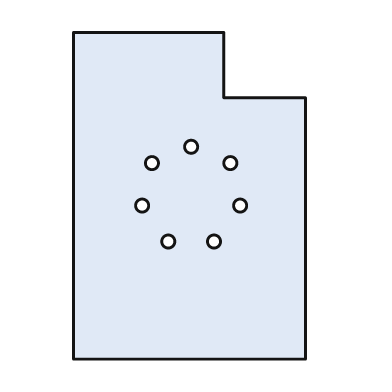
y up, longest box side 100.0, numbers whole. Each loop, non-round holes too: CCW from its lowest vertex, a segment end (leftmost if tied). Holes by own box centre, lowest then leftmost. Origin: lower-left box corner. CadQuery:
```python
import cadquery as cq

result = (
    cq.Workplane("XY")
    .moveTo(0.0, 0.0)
    .lineTo(71.0, 0.0)
    .lineTo(71.0, 80.0)
    .lineTo(46.0, 80.0)
    .lineTo(46.0, 100.0)
    .lineTo(0.0, 100.0)
    .close()
    .moveTo(29.0, 36.0)
    .circle(2.0)
    .moveTo(43.0, 36.0)
    .circle(2.0)
    .moveTo(21.0, 47.0)
    .circle(2.0)
    .moveTo(51.0, 47.0)
    .circle(2.0)
    .moveTo(24.0, 60.0)
    .circle(2.0)
    .moveTo(48.0, 60.0)
    .circle(2.0)
    .moveTo(36.0, 65.0)
    .circle(2.0)
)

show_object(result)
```